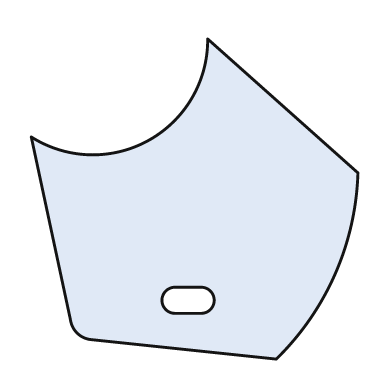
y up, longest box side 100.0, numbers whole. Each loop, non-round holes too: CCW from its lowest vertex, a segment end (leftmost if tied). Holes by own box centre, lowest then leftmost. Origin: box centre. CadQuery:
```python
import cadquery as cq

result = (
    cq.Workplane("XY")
    .moveTo(25.0, -49.0)
    .threePointArc((43.0, -23.0), (50.0, 8.0))
    .lineTo(4.0, 49.0)
    .threePointArc((-14.0, 18.0), (-50.0, 19.0))
    .lineTo(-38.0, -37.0)
    .threePointArc((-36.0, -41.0), (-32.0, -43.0))
    .close()
    .moveTo(-6.0, -35.0)
    .lineTo(2.0, -35.0)
    .threePointArc((6.0, -31.0), (2.0, -27.0))
    .lineTo(-6.0, -27.0)
    .threePointArc((-10.0, -31.0), (-6.0, -35.0))
    .close()
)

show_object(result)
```